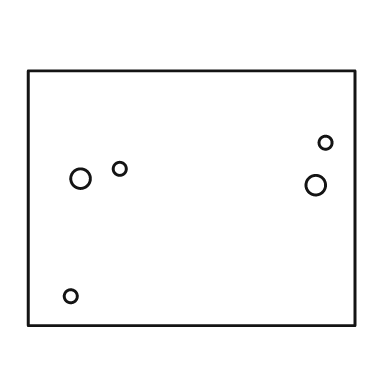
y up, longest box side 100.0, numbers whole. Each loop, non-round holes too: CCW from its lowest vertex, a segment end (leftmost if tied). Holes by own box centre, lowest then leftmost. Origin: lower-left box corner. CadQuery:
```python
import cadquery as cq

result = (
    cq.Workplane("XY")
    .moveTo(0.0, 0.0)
    .lineTo(100.0, 0.0)
    .lineTo(100.0, 78.0)
    .lineTo(0.0, 78.0)
    .close()
    .moveTo(13.0, 9.0)
    .circle(2.0)
    .moveTo(88.0, 43.0)
    .circle(3.0)
    .moveTo(16.0, 45.0)
    .circle(3.0)
    .moveTo(28.0, 48.0)
    .circle(2.0)
    .moveTo(91.0, 56.0)
    .circle(2.0)
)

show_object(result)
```